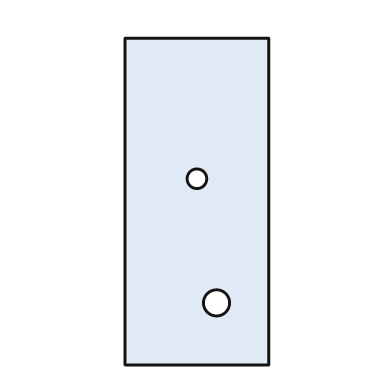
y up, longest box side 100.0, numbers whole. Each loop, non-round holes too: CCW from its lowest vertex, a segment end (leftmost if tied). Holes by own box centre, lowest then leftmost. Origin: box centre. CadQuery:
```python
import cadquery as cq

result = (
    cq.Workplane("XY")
    .moveTo(-22.0, -50.0)
    .lineTo(22.0, -50.0)
    .lineTo(22.0, 50.0)
    .lineTo(-22.0, 50.0)
    .close()
    .moveTo(6.0, -31.0)
    .circle(4.0)
    .moveTo(0.0, 7.0)
    .circle(3.0)
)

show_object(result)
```